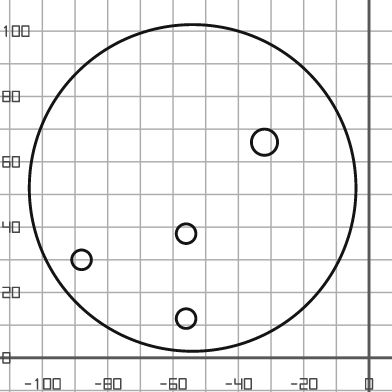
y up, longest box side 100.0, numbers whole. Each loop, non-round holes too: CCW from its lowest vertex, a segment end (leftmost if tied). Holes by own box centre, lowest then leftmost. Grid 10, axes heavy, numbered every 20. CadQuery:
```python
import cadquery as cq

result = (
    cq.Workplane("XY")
    .moveTo(-54.0, 52.0)
    .circle(50.0)
    .moveTo(-56.0, 12.0)
    .circle(3.0)
    .moveTo(-88.0, 30.0)
    .circle(3.0)
    .moveTo(-56.0, 38.0)
    .circle(3.0)
    .moveTo(-32.0, 66.0)
    .circle(4.0)
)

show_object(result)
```